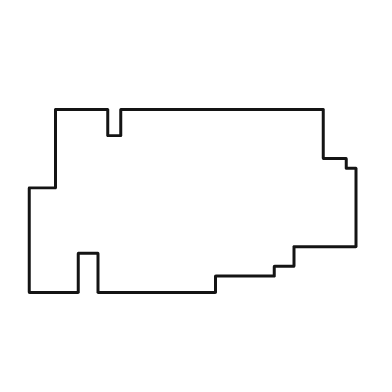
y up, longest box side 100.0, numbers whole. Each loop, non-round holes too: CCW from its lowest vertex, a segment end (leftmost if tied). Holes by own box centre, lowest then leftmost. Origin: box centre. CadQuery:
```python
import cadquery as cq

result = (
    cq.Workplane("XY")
    .moveTo(-50.0, -28.0)
    .lineTo(-35.0, -28.0)
    .lineTo(-35.0, -16.0)
    .lineTo(-29.0, -16.0)
    .lineTo(-29.0, -28.0)
    .lineTo(7.0, -28.0)
    .lineTo(7.0, -23.0)
    .lineTo(25.0, -23.0)
    .lineTo(25.0, -20.0)
    .lineTo(31.0, -20.0)
    .lineTo(31.0, -14.0)
    .lineTo(50.0, -14.0)
    .lineTo(50.0, 10.0)
    .lineTo(47.0, 10.0)
    .lineTo(47.0, 13.0)
    .lineTo(40.0, 13.0)
    .lineTo(40.0, 28.0)
    .lineTo(-22.0, 28.0)
    .lineTo(-22.0, 20.0)
    .lineTo(-26.0, 20.0)
    .lineTo(-26.0, 28.0)
    .lineTo(-42.0, 28.0)
    .lineTo(-42.0, 4.0)
    .lineTo(-50.0, 4.0)
    .close()
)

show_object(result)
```